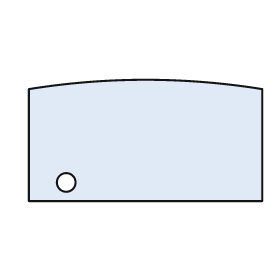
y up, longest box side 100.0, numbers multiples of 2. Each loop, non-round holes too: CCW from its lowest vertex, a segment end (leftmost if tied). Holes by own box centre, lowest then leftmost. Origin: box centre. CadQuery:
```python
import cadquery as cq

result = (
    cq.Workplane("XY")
    .moveTo(-50.0, -26.0)
    .lineTo(50.0, -26.0)
    .lineTo(50.0, 22.0)
    .threePointArc((0.0, 26.0), (-50.0, 22.0))
    .close()
    .moveTo(-34.0, -18.0)
    .circle(4.0)
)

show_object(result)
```